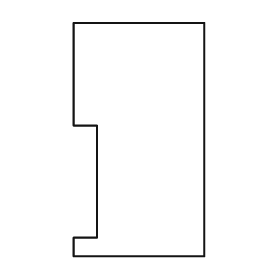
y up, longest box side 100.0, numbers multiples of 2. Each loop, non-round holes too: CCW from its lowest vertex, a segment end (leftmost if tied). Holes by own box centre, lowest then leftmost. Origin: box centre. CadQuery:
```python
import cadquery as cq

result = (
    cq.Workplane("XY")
    .moveTo(-28.0, -50.0)
    .lineTo(28.0, -50.0)
    .lineTo(28.0, 50.0)
    .lineTo(-28.0, 50.0)
    .lineTo(-28.0, 6.0)
    .lineTo(-18.0, 6.0)
    .lineTo(-18.0, -42.0)
    .lineTo(-28.0, -42.0)
    .close()
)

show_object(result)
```